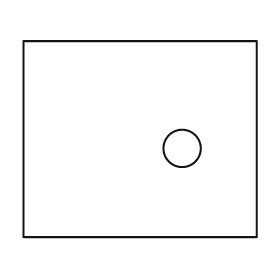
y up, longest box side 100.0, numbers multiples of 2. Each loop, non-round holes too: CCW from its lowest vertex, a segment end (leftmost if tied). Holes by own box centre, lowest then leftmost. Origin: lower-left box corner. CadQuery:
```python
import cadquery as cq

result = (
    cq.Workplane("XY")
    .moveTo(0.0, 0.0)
    .lineTo(100.0, 0.0)
    .lineTo(100.0, 84.0)
    .lineTo(0.0, 84.0)
    .close()
    .moveTo(68.0, 38.0)
    .circle(8.0)
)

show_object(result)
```